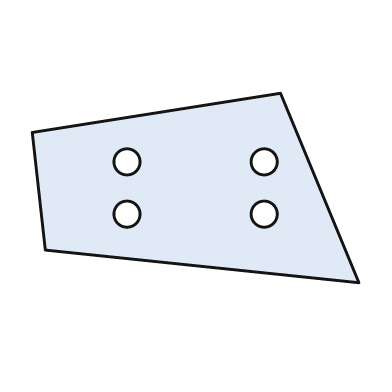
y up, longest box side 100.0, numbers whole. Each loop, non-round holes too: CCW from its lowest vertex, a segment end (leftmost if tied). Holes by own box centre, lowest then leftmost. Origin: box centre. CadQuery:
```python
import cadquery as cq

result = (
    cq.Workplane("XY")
    .moveTo(50.0, -29.0)
    .lineTo(26.0, 29.0)
    .lineTo(-50.0, 17.0)
    .lineTo(-46.0, -19.0)
    .close()
    .moveTo(-21.0, -8.0)
    .circle(4.0)
    .moveTo(21.0, -8.0)
    .circle(4.0)
    .moveTo(-21.0, 8.0)
    .circle(4.0)
    .moveTo(21.0, 8.0)
    .circle(4.0)
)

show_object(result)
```